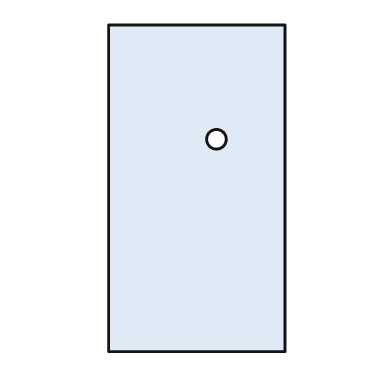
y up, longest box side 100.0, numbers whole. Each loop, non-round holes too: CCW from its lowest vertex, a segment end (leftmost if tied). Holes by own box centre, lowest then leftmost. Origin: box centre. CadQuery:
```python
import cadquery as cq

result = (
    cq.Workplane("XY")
    .moveTo(-27.0, -50.0)
    .lineTo(27.0, -50.0)
    .lineTo(27.0, 50.0)
    .lineTo(-27.0, 50.0)
    .close()
    .moveTo(6.0, 15.0)
    .circle(3.0)
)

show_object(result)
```